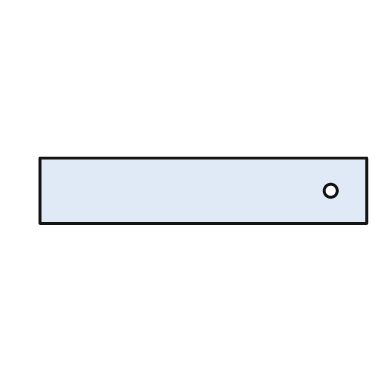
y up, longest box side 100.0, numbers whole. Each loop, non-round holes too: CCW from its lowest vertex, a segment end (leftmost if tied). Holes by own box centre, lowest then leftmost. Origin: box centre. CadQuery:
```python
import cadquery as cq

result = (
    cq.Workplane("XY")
    .moveTo(-50.0, -10.0)
    .lineTo(50.0, -10.0)
    .lineTo(50.0, 10.0)
    .lineTo(-50.0, 10.0)
    .close()
    .moveTo(39.0, 0.0)
    .circle(2.0)
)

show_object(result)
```